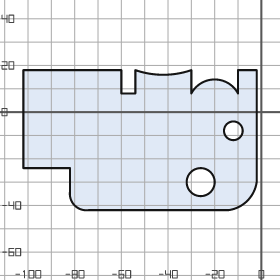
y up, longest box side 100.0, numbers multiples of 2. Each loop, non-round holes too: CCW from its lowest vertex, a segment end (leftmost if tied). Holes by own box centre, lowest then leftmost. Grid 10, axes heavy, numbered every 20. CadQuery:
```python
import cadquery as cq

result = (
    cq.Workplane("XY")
    .moveTo(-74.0, -42.0)
    .lineTo(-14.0, -42.0)
    .threePointArc((-6.0, -38.0), (-2.0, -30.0))
    .lineTo(-2.0, 18.0)
    .lineTo(-10.0, 18.0)
    .lineTo(-10.0, 8.0)
    .threePointArc((-20.0, 14.0), (-30.0, 8.0))
    .lineTo(-30.0, 18.0)
    .threePointArc((-42.0, 16.0), (-54.0, 18.0))
    .lineTo(-54.0, 8.0)
    .lineTo(-60.0, 8.0)
    .lineTo(-60.0, 18.0)
    .lineTo(-102.0, 18.0)
    .lineTo(-102.0, -24.0)
    .lineTo(-82.0, -24.0)
    .lineTo(-82.0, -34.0)
    .threePointArc((-80.0, -40.0), (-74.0, -42.0))
    .close()
    .moveTo(-26.0, -30.0)
    .circle(6.0)
    .moveTo(-12.0, -8.0)
    .circle(4.0)
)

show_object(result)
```